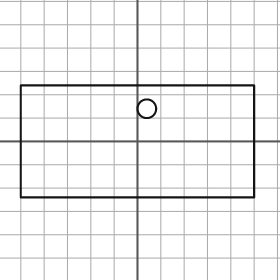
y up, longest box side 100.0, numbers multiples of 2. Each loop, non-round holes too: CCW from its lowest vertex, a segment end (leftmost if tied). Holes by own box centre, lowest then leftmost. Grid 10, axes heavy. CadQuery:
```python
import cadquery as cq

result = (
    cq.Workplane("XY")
    .moveTo(-50.0, -24.0)
    .lineTo(50.0, -24.0)
    .lineTo(50.0, 24.0)
    .lineTo(-50.0, 24.0)
    .close()
    .moveTo(4.0, 14.0)
    .circle(4.0)
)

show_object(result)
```